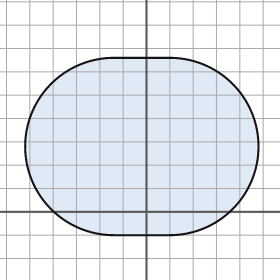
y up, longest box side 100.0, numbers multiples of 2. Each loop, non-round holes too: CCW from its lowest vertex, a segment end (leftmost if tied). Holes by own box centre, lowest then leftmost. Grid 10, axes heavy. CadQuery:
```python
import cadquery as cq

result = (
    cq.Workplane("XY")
    .moveTo(-14.0, -10.0)
    .lineTo(10.0, -10.0)
    .threePointArc((48.0, 28.0), (10.0, 66.0))
    .lineTo(-14.0, 66.0)
    .threePointArc((-52.0, 28.0), (-14.0, -10.0))
    .close()
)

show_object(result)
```